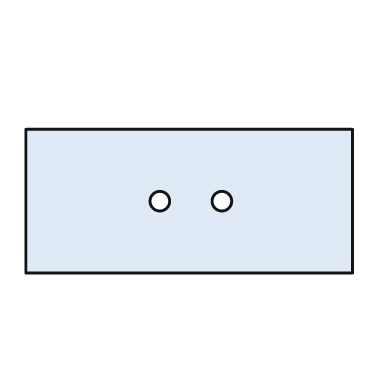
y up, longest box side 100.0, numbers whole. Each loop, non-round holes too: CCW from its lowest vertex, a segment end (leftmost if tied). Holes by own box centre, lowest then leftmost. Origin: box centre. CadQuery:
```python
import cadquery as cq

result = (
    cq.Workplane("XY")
    .moveTo(-50.0, -22.0)
    .lineTo(50.0, -22.0)
    .lineTo(50.0, 22.0)
    .lineTo(-50.0, 22.0)
    .close()
    .moveTo(-9.0, 0.0)
    .circle(3.0)
    .moveTo(10.0, 0.0)
    .circle(3.0)
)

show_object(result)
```